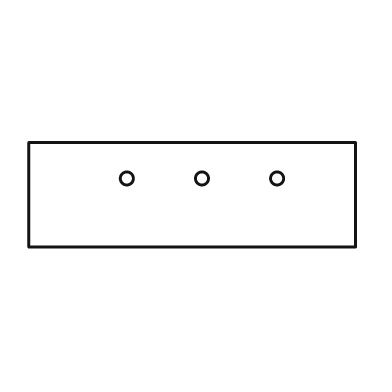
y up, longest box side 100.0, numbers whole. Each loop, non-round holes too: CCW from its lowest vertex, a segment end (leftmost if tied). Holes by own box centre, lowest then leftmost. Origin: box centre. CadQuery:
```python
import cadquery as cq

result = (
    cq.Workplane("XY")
    .moveTo(-50.0, -16.0)
    .lineTo(50.0, -16.0)
    .lineTo(50.0, 16.0)
    .lineTo(-50.0, 16.0)
    .close()
    .moveTo(-20.0, 5.0)
    .circle(2.0)
    .moveTo(3.0, 5.0)
    .circle(2.0)
    .moveTo(26.0, 5.0)
    .circle(2.0)
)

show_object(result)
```